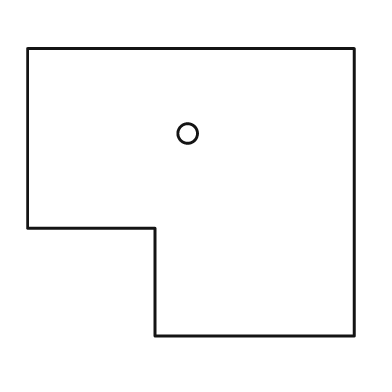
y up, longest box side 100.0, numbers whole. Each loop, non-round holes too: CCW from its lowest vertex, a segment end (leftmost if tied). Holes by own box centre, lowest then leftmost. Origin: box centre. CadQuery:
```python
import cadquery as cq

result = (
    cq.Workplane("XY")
    .moveTo(-11.0, -44.0)
    .lineTo(50.0, -44.0)
    .lineTo(50.0, 44.0)
    .lineTo(-50.0, 44.0)
    .lineTo(-50.0, -11.0)
    .lineTo(-11.0, -11.0)
    .close()
    .moveTo(-1.0, 18.0)
    .circle(3.0)
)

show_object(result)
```